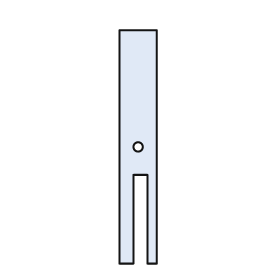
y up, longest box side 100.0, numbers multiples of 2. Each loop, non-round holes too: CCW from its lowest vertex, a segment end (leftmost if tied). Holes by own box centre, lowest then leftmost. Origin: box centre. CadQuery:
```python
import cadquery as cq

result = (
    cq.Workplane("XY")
    .moveTo(-8.0, -50.0)
    .lineTo(-2.0, -50.0)
    .lineTo(-2.0, -12.0)
    .lineTo(4.0, -12.0)
    .lineTo(4.0, -50.0)
    .lineTo(8.0, -50.0)
    .lineTo(8.0, 50.0)
    .lineTo(-8.0, 50.0)
    .close()
    .moveTo(0.0, 0.0)
    .circle(2.0)
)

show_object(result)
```